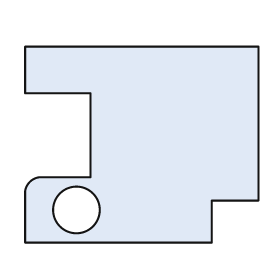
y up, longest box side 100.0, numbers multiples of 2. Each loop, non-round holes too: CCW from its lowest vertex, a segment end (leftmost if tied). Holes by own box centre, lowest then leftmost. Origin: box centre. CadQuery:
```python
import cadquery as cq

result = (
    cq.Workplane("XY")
    .moveTo(-50.0, -42.0)
    .lineTo(30.0, -42.0)
    .lineTo(30.0, -24.0)
    .lineTo(50.0, -24.0)
    .lineTo(50.0, 42.0)
    .lineTo(-50.0, 42.0)
    .lineTo(-50.0, 22.0)
    .lineTo(-22.0, 22.0)
    .lineTo(-22.0, -14.0)
    .lineTo(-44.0, -14.0)
    .threePointArc((-48.0, -16.0), (-50.0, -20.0))
    .close()
    .moveTo(-28.0, -28.0)
    .circle(10.0)
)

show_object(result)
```